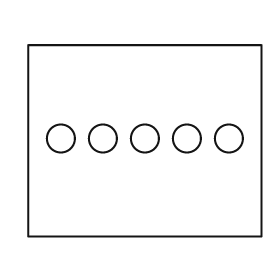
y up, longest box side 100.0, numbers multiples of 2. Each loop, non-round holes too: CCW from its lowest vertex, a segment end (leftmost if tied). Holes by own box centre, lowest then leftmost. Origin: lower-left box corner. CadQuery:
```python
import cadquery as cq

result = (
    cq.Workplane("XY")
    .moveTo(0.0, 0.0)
    .lineTo(100.0, 0.0)
    .lineTo(100.0, 82.0)
    .lineTo(0.0, 82.0)
    .close()
    .moveTo(14.0, 42.0)
    .circle(6.0)
    .moveTo(32.0, 42.0)
    .circle(6.0)
    .moveTo(50.0, 42.0)
    .circle(6.0)
    .moveTo(68.0, 42.0)
    .circle(6.0)
    .moveTo(86.0, 42.0)
    .circle(6.0)
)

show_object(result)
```